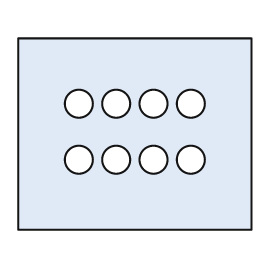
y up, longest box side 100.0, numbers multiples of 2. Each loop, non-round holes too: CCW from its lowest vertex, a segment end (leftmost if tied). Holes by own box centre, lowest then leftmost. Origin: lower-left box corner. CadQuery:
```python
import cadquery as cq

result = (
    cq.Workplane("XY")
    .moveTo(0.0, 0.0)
    .lineTo(100.0, 0.0)
    .lineTo(100.0, 82.0)
    .lineTo(0.0, 82.0)
    .close()
    .moveTo(26.0, 30.0)
    .circle(6.0)
    .moveTo(42.0, 30.0)
    .circle(6.0)
    .moveTo(58.0, 30.0)
    .circle(6.0)
    .moveTo(74.0, 30.0)
    .circle(6.0)
    .moveTo(26.0, 54.0)
    .circle(6.0)
    .moveTo(42.0, 54.0)
    .circle(6.0)
    .moveTo(58.0, 54.0)
    .circle(6.0)
    .moveTo(74.0, 54.0)
    .circle(6.0)
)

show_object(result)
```